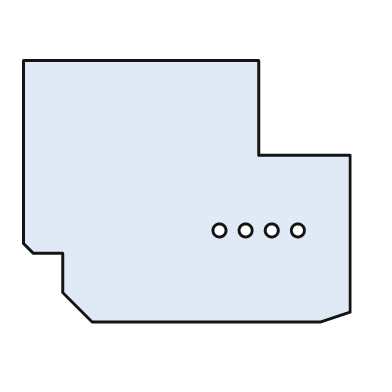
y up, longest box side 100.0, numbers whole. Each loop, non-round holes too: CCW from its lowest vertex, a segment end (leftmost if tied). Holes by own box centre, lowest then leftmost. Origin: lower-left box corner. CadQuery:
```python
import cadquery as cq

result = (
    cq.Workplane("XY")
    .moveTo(21.0, 0.0)
    .lineTo(91.0, 0.0)
    .lineTo(100.0, 3.0)
    .lineTo(100.0, 51.0)
    .lineTo(72.0, 51.0)
    .lineTo(72.0, 80.0)
    .lineTo(0.0, 80.0)
    .lineTo(0.0, 24.0)
    .lineTo(3.0, 21.0)
    .lineTo(12.0, 21.0)
    .lineTo(12.0, 9.0)
    .close()
    .moveTo(60.0, 28.0)
    .circle(2.0)
    .moveTo(68.0, 28.0)
    .circle(2.0)
    .moveTo(76.0, 28.0)
    .circle(2.0)
    .moveTo(84.0, 28.0)
    .circle(2.0)
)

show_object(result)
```